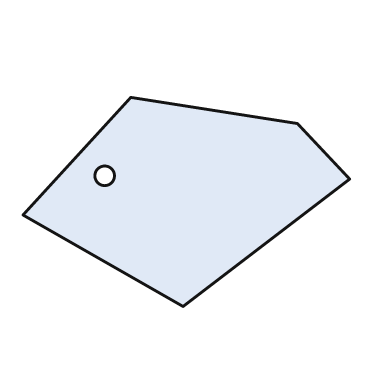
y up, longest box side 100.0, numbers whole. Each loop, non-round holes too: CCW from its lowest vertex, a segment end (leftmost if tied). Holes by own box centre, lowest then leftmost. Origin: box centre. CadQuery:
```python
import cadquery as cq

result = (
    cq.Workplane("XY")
    .moveTo(-1.0, -32.0)
    .lineTo(50.0, 7.0)
    .lineTo(34.0, 24.0)
    .lineTo(-17.0, 32.0)
    .lineTo(-50.0, -4.0)
    .close()
    .moveTo(-25.0, 8.0)
    .circle(3.0)
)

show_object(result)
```